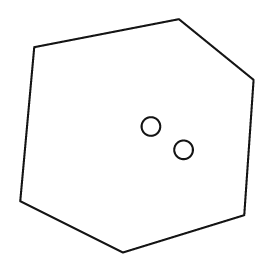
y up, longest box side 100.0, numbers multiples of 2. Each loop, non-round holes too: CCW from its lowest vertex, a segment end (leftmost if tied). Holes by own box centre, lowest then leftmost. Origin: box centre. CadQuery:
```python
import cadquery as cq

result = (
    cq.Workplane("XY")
    .moveTo(-6.0, -50.0)
    .lineTo(46.0, -34.0)
    .lineTo(50.0, 24.0)
    .lineTo(18.0, 50.0)
    .lineTo(-44.0, 38.0)
    .lineTo(-50.0, -28.0)
    .close()
    .moveTo(20.0, -6.0)
    .circle(4.0)
    .moveTo(6.0, 4.0)
    .circle(4.0)
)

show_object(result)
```